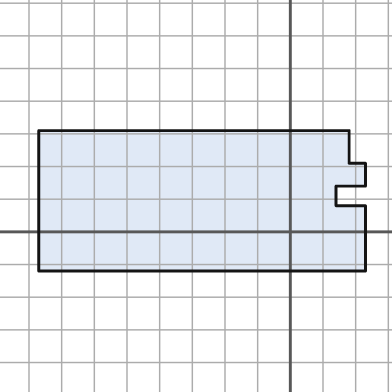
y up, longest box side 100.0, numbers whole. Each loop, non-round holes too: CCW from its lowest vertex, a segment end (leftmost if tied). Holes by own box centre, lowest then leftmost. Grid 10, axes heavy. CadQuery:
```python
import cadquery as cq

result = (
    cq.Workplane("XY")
    .moveTo(-77.0, -12.0)
    .lineTo(23.0, -12.0)
    .lineTo(23.0, 8.0)
    .lineTo(14.0, 8.0)
    .lineTo(14.0, 14.0)
    .lineTo(23.0, 14.0)
    .lineTo(23.0, 21.0)
    .lineTo(18.0, 21.0)
    .lineTo(18.0, 31.0)
    .lineTo(-77.0, 31.0)
    .close()
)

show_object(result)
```